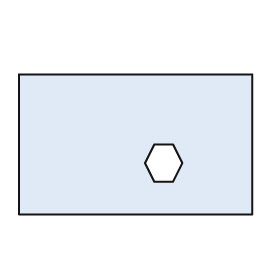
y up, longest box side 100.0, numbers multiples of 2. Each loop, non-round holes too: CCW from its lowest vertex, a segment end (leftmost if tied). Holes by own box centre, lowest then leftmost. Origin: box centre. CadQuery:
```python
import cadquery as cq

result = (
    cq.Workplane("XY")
    .moveTo(-50.0, -30.0)
    .lineTo(50.0, -30.0)
    .lineTo(50.0, 30.0)
    .lineTo(-50.0, 30.0)
    .close()
    .moveTo(8.0, -16.0)
    .lineTo(16.0, -16.0)
    .lineTo(20.0, -8.0)
    .lineTo(16.0, 0.0)
    .lineTo(8.0, 0.0)
    .lineTo(4.0, -8.0)
    .close()
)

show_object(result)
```